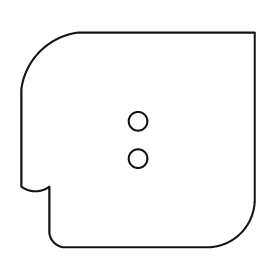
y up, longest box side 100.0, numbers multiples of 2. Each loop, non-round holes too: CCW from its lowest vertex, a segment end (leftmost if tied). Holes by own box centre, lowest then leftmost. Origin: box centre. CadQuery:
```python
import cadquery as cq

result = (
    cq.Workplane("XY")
    .moveTo(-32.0, -46.0)
    .lineTo(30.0, -46.0)
    .threePointArc((44.0, -40.0), (50.0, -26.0))
    .lineTo(50.0, 46.0)
    .lineTo(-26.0, 46.0)
    .threePointArc((-42.0, 38.0), (-50.0, 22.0))
    .lineTo(-50.0, -20.0)
    .threePointArc((-44.0, -22.0), (-38.0, -20.0))
    .lineTo(-38.0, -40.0)
    .threePointArc((-36.0, -44.0), (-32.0, -46.0))
    .close()
    .moveTo(0.0, -8.0)
    .circle(4.0)
    .moveTo(0.0, 8.0)
    .circle(4.0)
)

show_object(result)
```